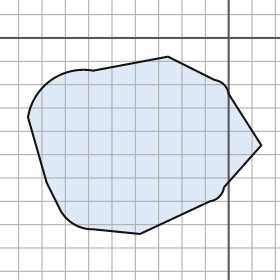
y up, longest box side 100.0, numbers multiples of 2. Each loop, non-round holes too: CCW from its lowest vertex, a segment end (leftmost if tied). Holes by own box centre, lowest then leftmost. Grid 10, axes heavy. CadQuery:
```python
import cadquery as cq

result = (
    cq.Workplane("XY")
    .moveTo(-38.0, -84.0)
    .lineTo(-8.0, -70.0)
    .threePointArc((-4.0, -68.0), (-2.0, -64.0))
    .lineTo(14.0, -46.0)
    .lineTo(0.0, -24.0)
    .threePointArc((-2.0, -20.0), (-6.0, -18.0))
    .lineTo(-26.0, -8.0)
    .lineTo(-58.0, -14.0)
    .threePointArc((-76.0, -18.0), (-86.0, -34.0))
    .lineTo(-78.0, -62.0)
    .lineTo(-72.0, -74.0)
    .threePointArc((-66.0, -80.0), (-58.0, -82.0))
    .close()
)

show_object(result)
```